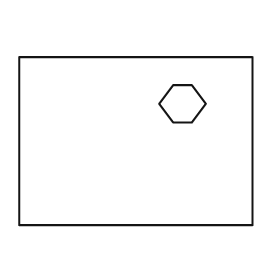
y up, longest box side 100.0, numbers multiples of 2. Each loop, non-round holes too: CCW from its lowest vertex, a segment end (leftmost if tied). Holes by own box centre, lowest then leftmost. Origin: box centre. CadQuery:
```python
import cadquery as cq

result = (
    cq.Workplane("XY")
    .moveTo(-50.0, -36.0)
    .lineTo(50.0, -36.0)
    .lineTo(50.0, 36.0)
    .lineTo(-50.0, 36.0)
    .close()
    .moveTo(16.0, 8.0)
    .lineTo(24.0, 8.0)
    .lineTo(30.0, 16.0)
    .lineTo(24.0, 24.0)
    .lineTo(16.0, 24.0)
    .lineTo(10.0, 16.0)
    .close()
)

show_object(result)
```